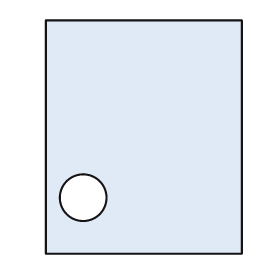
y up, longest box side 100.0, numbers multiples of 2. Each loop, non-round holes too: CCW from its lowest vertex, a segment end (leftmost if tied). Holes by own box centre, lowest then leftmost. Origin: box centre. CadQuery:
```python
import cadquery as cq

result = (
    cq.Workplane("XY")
    .moveTo(-42.0, -50.0)
    .lineTo(42.0, -50.0)
    .lineTo(42.0, 50.0)
    .lineTo(-42.0, 50.0)
    .close()
    .moveTo(-26.0, -26.0)
    .circle(10.0)
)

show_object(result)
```